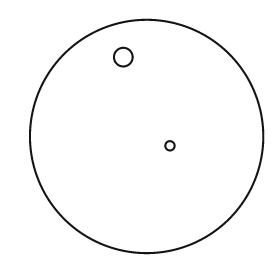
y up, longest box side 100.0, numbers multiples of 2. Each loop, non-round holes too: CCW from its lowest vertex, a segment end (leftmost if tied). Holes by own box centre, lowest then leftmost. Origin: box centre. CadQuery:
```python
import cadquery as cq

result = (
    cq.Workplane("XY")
    .moveTo(0.0, 0.0)
    .circle(50.0)
    .moveTo(10.0, -4.0)
    .circle(2.0)
    .moveTo(-10.0, 34.0)
    .circle(4.0)
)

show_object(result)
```